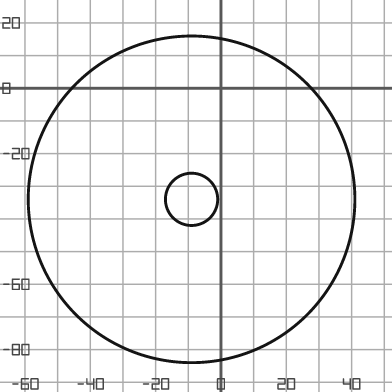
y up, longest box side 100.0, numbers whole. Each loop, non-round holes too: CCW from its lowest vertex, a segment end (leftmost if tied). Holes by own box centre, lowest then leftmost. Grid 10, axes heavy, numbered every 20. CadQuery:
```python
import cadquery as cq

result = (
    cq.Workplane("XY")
    .moveTo(-9.0, -34.0)
    .circle(50.0)
    .moveTo(-9.0, -34.0)
    .circle(8.0)
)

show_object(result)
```